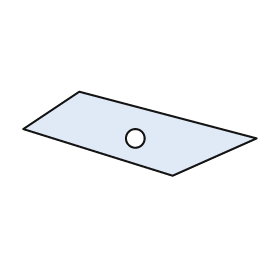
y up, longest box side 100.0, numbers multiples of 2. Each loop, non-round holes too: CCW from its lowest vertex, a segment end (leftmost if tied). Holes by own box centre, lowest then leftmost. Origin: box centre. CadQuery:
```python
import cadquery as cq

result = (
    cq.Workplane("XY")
    .moveTo(14.0, -18.0)
    .lineTo(50.0, -2.0)
    .lineTo(-26.0, 18.0)
    .lineTo(-50.0, 2.0)
    .close()
    .moveTo(-2.0, -2.0)
    .circle(4.0)
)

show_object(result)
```